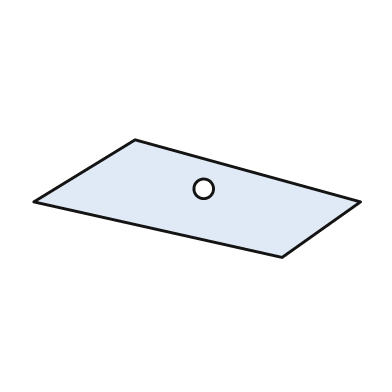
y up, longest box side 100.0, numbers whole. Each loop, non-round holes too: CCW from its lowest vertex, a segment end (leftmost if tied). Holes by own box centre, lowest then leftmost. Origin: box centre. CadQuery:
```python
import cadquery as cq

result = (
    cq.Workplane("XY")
    .moveTo(26.0, -18.0)
    .lineTo(50.0, -1.0)
    .lineTo(-19.0, 18.0)
    .lineTo(-50.0, -1.0)
    .close()
    .moveTo(2.0, 3.0)
    .circle(3.0)
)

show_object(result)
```